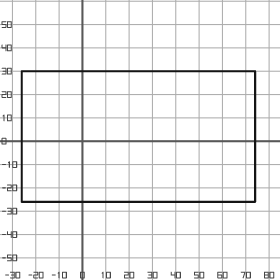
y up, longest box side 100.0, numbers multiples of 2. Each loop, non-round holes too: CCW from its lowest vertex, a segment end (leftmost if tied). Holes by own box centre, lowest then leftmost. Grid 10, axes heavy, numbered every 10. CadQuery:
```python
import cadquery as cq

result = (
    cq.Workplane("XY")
    .moveTo(-26.0, -26.0)
    .lineTo(74.0, -26.0)
    .lineTo(74.0, 30.0)
    .lineTo(-26.0, 30.0)
    .close()
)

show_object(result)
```